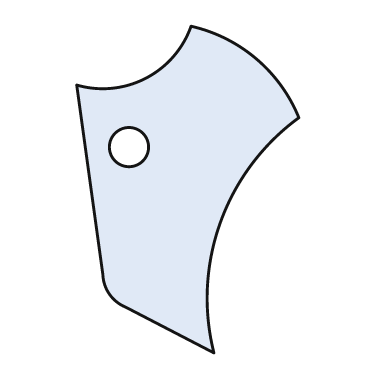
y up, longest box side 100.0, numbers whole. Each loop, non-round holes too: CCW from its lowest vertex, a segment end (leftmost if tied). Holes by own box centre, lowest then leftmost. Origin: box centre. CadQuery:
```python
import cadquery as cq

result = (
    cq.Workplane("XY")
    .moveTo(8.0, -50.0)
    .threePointArc((10.0, -10.0), (34.0, 22.0))
    .threePointArc((21.0, 40.0), (1.0, 50.0))
    .threePointArc((-13.0, 34.0), (-34.0, 32.0))
    .lineTo(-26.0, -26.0)
    .threePointArc((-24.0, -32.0), (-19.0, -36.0))
    .close()
    .moveTo(-18.0, 13.0)
    .circle(6.0)
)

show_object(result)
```